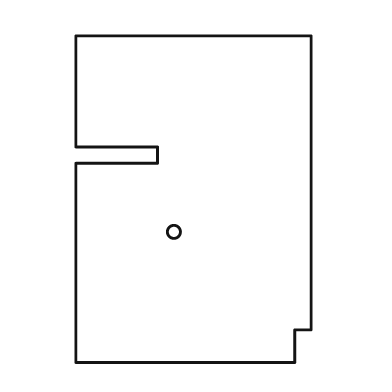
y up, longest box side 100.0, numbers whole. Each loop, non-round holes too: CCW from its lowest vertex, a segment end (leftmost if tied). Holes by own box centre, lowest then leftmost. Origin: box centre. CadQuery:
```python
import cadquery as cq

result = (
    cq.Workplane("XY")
    .moveTo(-36.0, -50.0)
    .lineTo(31.0, -50.0)
    .lineTo(31.0, -40.0)
    .lineTo(36.0, -40.0)
    .lineTo(36.0, 50.0)
    .lineTo(-36.0, 50.0)
    .lineTo(-36.0, 16.0)
    .lineTo(-11.0, 16.0)
    .lineTo(-11.0, 11.0)
    .lineTo(-36.0, 11.0)
    .close()
    .moveTo(-6.0, -10.0)
    .circle(2.0)
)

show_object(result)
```